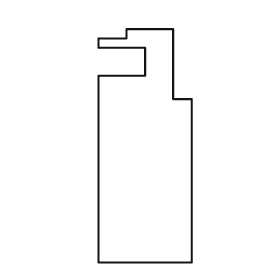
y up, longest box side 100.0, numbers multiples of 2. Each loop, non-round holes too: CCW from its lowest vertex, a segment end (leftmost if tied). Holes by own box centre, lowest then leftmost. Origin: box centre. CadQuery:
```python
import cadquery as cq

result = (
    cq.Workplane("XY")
    .moveTo(-20.0, -50.0)
    .lineTo(20.0, -50.0)
    .lineTo(20.0, 20.0)
    .lineTo(12.0, 20.0)
    .lineTo(12.0, 50.0)
    .lineTo(-8.0, 50.0)
    .lineTo(-8.0, 46.0)
    .lineTo(-20.0, 46.0)
    .lineTo(-20.0, 42.0)
    .lineTo(0.0, 42.0)
    .lineTo(0.0, 30.0)
    .lineTo(-20.0, 30.0)
    .close()
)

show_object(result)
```